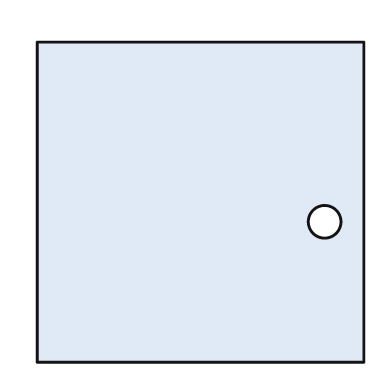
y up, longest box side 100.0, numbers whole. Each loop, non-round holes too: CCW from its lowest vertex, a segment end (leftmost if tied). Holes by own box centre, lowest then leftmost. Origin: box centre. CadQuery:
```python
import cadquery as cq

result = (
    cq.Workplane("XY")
    .moveTo(-50.0, -49.0)
    .lineTo(50.0, -49.0)
    .lineTo(50.0, 49.0)
    .lineTo(-50.0, 49.0)
    .close()
    .moveTo(38.0, -6.0)
    .circle(5.0)
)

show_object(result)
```